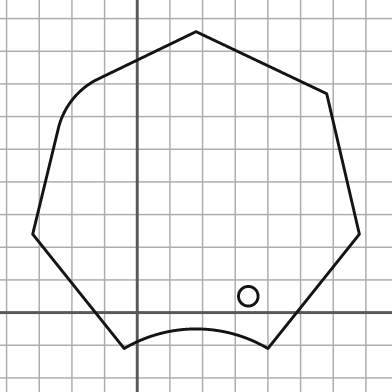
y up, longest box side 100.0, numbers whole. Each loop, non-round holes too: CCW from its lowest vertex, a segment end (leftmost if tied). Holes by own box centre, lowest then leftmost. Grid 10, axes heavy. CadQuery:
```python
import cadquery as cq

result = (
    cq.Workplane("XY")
    .moveTo(-4.0, -11.0)
    .threePointArc((18.0, -5.0), (40.0, -11.0))
    .lineTo(68.0, 24.0)
    .lineTo(58.0, 67.0)
    .lineTo(18.0, 86.0)
    .lineTo(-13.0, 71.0)
    .threePointArc((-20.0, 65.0), (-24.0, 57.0))
    .lineTo(-32.0, 24.0)
    .close()
    .moveTo(34.0, 5.0)
    .circle(3.0)
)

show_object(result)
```